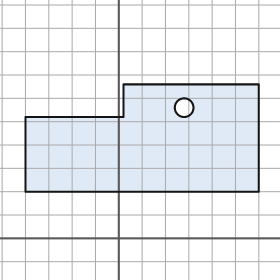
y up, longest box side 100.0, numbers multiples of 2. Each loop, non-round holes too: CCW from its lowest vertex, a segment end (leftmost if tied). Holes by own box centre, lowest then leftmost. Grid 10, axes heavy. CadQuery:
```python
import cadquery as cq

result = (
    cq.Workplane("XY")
    .moveTo(-40.0, 20.0)
    .lineTo(60.0, 20.0)
    .lineTo(60.0, 66.0)
    .lineTo(2.0, 66.0)
    .lineTo(2.0, 52.0)
    .lineTo(-40.0, 52.0)
    .close()
    .moveTo(28.0, 56.0)
    .circle(4.0)
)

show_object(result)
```